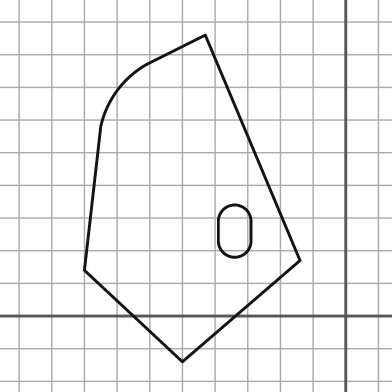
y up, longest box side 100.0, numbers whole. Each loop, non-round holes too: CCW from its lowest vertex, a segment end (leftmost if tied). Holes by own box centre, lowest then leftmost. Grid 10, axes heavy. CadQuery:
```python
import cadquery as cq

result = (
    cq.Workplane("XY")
    .moveTo(-50.0, -14.0)
    .lineTo(-14.0, 17.0)
    .lineTo(-43.0, 86.0)
    .lineTo(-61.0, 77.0)
    .threePointArc((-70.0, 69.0), (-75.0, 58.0))
    .lineTo(-80.0, 14.0)
    .close()
    .moveTo(-39.0, 23.0)
    .threePointArc((-34.0, 18.0), (-29.0, 23.0))
    .lineTo(-29.0, 29.0)
    .threePointArc((-34.0, 34.0), (-39.0, 29.0))
    .close()
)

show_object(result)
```